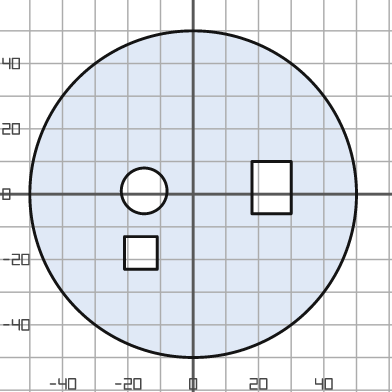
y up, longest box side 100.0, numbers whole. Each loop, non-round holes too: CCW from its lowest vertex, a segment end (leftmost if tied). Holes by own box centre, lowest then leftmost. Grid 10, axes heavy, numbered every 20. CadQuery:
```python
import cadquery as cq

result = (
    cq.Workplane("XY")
    .moveTo(0.0, 0.0)
    .circle(50.0)
    .moveTo(-21.0, -23.0)
    .lineTo(-11.0, -23.0)
    .lineTo(-11.0, -13.0)
    .lineTo(-21.0, -13.0)
    .close()
    .moveTo(-15.0, 1.0)
    .circle(7.0)
    .moveTo(18.0, -6.0)
    .lineTo(30.0, -6.0)
    .lineTo(30.0, 10.0)
    .lineTo(18.0, 10.0)
    .close()
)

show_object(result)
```